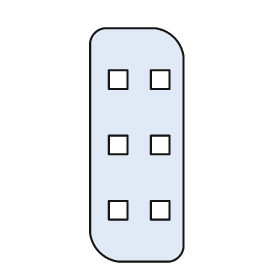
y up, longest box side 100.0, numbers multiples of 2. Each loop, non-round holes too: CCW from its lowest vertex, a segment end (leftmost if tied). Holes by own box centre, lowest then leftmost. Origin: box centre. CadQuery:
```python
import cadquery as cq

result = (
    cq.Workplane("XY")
    .moveTo(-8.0, -50.0)
    .lineTo(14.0, -50.0)
    .threePointArc((18.0, -48.0), (20.0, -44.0))
    .lineTo(20.0, 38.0)
    .threePointArc((16.0, 46.0), (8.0, 50.0))
    .lineTo(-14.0, 50.0)
    .threePointArc((-18.0, 48.0), (-20.0, 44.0))
    .lineTo(-20.0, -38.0)
    .threePointArc((-16.0, -46.0), (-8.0, -50.0))
    .close()
    .moveTo(-12.0, -32.0)
    .lineTo(-4.0, -32.0)
    .lineTo(-4.0, -24.0)
    .lineTo(-12.0, -24.0)
    .close()
    .moveTo(6.0, -32.0)
    .lineTo(14.0, -32.0)
    .lineTo(14.0, -24.0)
    .lineTo(6.0, -24.0)
    .close()
    .moveTo(-12.0, -4.0)
    .lineTo(-4.0, -4.0)
    .lineTo(-4.0, 4.0)
    .lineTo(-12.0, 4.0)
    .close()
    .moveTo(6.0, -4.0)
    .lineTo(14.0, -4.0)
    .lineTo(14.0, 4.0)
    .lineTo(6.0, 4.0)
    .close()
    .moveTo(-12.0, 24.0)
    .lineTo(-4.0, 24.0)
    .lineTo(-4.0, 32.0)
    .lineTo(-12.0, 32.0)
    .close()
    .moveTo(6.0, 24.0)
    .lineTo(14.0, 24.0)
    .lineTo(14.0, 32.0)
    .lineTo(6.0, 32.0)
    .close()
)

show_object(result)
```